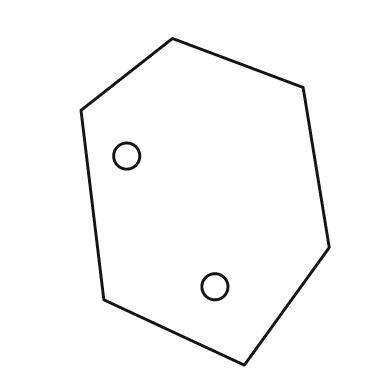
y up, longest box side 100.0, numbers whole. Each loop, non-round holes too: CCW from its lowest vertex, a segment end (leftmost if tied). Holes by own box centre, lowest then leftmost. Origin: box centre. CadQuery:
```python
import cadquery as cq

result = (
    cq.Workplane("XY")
    .moveTo(12.0, -50.0)
    .lineTo(38.0, -14.0)
    .lineTo(30.0, 35.0)
    .lineTo(-10.0, 50.0)
    .lineTo(-38.0, 28.0)
    .lineTo(-31.0, -30.0)
    .close()
    .moveTo(3.0, -26.0)
    .circle(4.0)
    .moveTo(-24.0, 14.0)
    .circle(4.0)
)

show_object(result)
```